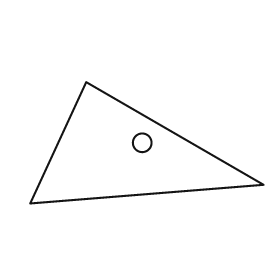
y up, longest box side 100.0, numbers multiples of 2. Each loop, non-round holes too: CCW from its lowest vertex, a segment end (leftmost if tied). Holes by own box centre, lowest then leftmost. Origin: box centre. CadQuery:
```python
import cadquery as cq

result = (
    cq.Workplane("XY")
    .moveTo(-50.0, -26.0)
    .lineTo(50.0, -18.0)
    .lineTo(-26.0, 26.0)
    .close()
    .moveTo(-2.0, 0.0)
    .circle(4.0)
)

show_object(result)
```